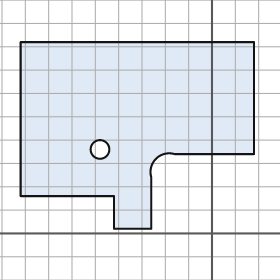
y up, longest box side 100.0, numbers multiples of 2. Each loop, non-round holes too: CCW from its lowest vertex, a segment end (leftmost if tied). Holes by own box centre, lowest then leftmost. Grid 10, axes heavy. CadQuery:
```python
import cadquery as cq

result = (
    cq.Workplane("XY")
    .moveTo(-42.0, 2.0)
    .lineTo(-26.0, 2.0)
    .lineTo(-26.0, 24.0)
    .threePointArc((-24.0, 32.0), (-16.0, 34.0))
    .lineTo(18.0, 34.0)
    .lineTo(18.0, 82.0)
    .lineTo(-82.0, 82.0)
    .lineTo(-82.0, 16.0)
    .lineTo(-42.0, 16.0)
    .close()
    .moveTo(-48.0, 36.0)
    .circle(4.0)
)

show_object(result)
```